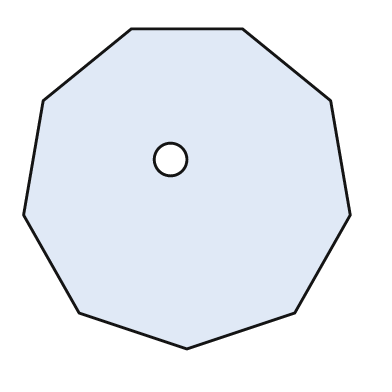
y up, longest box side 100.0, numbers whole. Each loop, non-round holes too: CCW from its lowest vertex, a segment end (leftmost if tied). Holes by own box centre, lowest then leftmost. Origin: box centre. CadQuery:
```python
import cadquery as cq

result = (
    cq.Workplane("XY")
    .moveTo(0.0, -49.0)
    .lineTo(33.0, -38.0)
    .lineTo(50.0, -8.0)
    .lineTo(44.0, 27.0)
    .lineTo(17.0, 49.0)
    .lineTo(-17.0, 49.0)
    .lineTo(-44.0, 27.0)
    .lineTo(-50.0, -8.0)
    .lineTo(-33.0, -38.0)
    .close()
    .moveTo(-5.0, 9.0)
    .circle(5.0)
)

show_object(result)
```